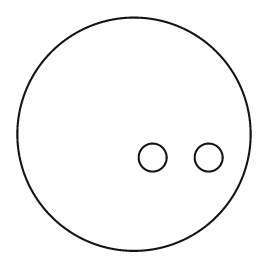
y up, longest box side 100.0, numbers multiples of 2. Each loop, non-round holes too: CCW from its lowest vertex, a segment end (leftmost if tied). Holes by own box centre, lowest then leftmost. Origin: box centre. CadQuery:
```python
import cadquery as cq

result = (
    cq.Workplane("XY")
    .moveTo(0.0, 0.0)
    .circle(50.0)
    .moveTo(8.0, -10.0)
    .circle(6.0)
    .moveTo(32.0, -10.0)
    .circle(6.0)
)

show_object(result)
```